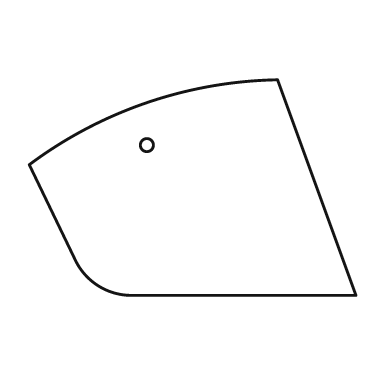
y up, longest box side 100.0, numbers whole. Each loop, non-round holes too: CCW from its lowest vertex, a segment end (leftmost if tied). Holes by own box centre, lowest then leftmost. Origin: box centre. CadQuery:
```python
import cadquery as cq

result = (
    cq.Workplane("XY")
    .moveTo(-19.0, -33.0)
    .lineTo(50.0, -33.0)
    .lineTo(26.0, 33.0)
    .threePointArc((-14.0, 26.0), (-50.0, 7.0))
    .lineTo(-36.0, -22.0)
    .threePointArc((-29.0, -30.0), (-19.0, -33.0))
    .close()
    .moveTo(-14.0, 13.0)
    .circle(2.0)
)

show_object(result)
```